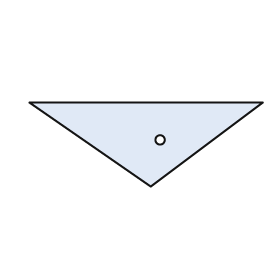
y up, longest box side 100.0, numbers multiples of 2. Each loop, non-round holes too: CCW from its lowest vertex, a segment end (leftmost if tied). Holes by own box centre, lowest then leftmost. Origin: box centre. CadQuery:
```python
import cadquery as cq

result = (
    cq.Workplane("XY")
    .moveTo(2.0, -18.0)
    .lineTo(50.0, 18.0)
    .lineTo(-50.0, 18.0)
    .close()
    .moveTo(6.0, 2.0)
    .circle(2.0)
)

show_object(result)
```